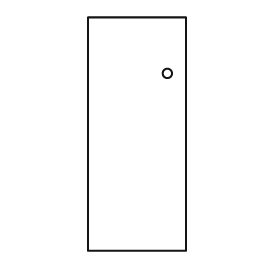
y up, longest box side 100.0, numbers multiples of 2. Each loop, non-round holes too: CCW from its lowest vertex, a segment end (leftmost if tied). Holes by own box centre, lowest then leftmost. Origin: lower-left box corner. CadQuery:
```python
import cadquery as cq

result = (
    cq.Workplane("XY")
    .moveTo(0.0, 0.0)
    .lineTo(42.0, 0.0)
    .lineTo(42.0, 100.0)
    .lineTo(0.0, 100.0)
    .close()
    .moveTo(34.0, 76.0)
    .circle(2.0)
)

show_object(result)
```